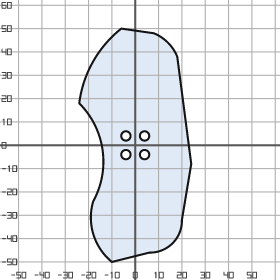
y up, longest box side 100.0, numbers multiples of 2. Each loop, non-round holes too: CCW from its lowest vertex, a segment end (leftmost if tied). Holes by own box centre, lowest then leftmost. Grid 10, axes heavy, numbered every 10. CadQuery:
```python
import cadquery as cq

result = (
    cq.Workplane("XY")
    .moveTo(-10.0, -50.0)
    .lineTo(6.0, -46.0)
    .threePointArc((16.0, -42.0), (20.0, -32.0))
    .lineTo(24.0, -8.0)
    .lineTo(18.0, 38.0)
    .threePointArc((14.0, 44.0), (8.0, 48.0))
    .lineTo(-6.0, 50.0)
    .threePointArc((-18.0, 36.0), (-24.0, 18.0))
    .threePointArc((-14.0, -2.0), (-18.0, -24.0))
    .threePointArc((-18.0, -38.0), (-10.0, -50.0))
    .close()
    .moveTo(-4.0, -4.0)
    .circle(2.0)
    .moveTo(4.0, -4.0)
    .circle(2.0)
    .moveTo(-4.0, 4.0)
    .circle(2.0)
    .moveTo(4.0, 4.0)
    .circle(2.0)
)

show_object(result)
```